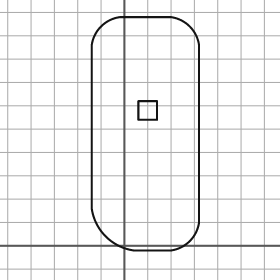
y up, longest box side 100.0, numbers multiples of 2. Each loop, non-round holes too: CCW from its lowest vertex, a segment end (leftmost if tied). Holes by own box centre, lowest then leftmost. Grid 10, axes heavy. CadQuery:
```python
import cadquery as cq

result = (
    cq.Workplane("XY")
    .moveTo(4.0, -2.0)
    .lineTo(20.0, -2.0)
    .threePointArc((28.0, 2.0), (32.0, 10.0))
    .lineTo(32.0, 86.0)
    .threePointArc((28.0, 94.0), (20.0, 98.0))
    .lineTo(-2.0, 98.0)
    .threePointArc((-10.0, 94.0), (-14.0, 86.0))
    .lineTo(-14.0, 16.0)
    .threePointArc((-8.0, 4.0), (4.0, -2.0))
    .close()
    .moveTo(6.0, 54.0)
    .lineTo(14.0, 54.0)
    .lineTo(14.0, 62.0)
    .lineTo(6.0, 62.0)
    .close()
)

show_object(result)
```